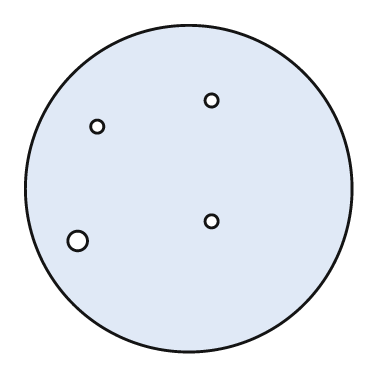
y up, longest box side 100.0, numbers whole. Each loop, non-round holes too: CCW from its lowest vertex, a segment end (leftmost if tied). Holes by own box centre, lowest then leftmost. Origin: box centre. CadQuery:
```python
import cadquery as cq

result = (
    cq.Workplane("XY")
    .moveTo(0.0, 0.0)
    .circle(50.0)
    .moveTo(-34.0, -16.0)
    .circle(3.0)
    .moveTo(7.0, -10.0)
    .circle(2.0)
    .moveTo(-28.0, 19.0)
    .circle(2.0)
    .moveTo(7.0, 27.0)
    .circle(2.0)
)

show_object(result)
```